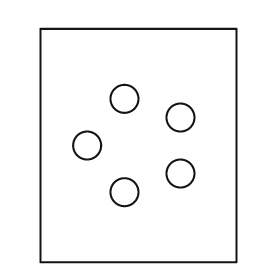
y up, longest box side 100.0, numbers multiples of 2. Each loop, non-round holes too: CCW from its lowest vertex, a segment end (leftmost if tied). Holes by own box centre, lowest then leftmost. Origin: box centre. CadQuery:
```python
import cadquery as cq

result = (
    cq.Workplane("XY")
    .moveTo(-42.0, -50.0)
    .lineTo(42.0, -50.0)
    .lineTo(42.0, 50.0)
    .lineTo(-42.0, 50.0)
    .close()
    .moveTo(-6.0, -20.0)
    .circle(6.0)
    .moveTo(18.0, -12.0)
    .circle(6.0)
    .moveTo(-22.0, 0.0)
    .circle(6.0)
    .moveTo(18.0, 12.0)
    .circle(6.0)
    .moveTo(-6.0, 20.0)
    .circle(6.0)
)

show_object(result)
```